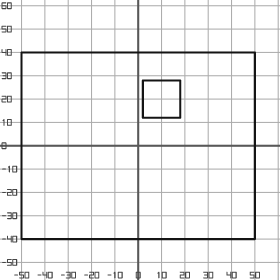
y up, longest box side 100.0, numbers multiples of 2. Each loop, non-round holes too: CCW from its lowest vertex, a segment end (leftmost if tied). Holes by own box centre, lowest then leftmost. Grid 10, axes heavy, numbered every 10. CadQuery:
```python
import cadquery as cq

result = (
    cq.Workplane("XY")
    .moveTo(-50.0, -40.0)
    .lineTo(50.0, -40.0)
    .lineTo(50.0, 40.0)
    .lineTo(-50.0, 40.0)
    .close()
    .moveTo(2.0, 12.0)
    .lineTo(18.0, 12.0)
    .lineTo(18.0, 28.0)
    .lineTo(2.0, 28.0)
    .close()
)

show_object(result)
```